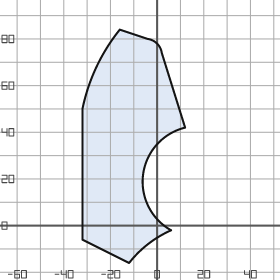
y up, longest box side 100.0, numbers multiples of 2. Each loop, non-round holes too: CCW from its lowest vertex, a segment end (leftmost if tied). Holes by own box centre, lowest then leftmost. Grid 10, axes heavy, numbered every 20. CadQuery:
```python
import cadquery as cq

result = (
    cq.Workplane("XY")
    .moveTo(-12.0, -16.0)
    .threePointArc((-4.0, -8.0), (6.0, -2.0))
    .threePointArc((-6.0, 22.0), (12.0, 42.0))
    .lineTo(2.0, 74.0)
    .threePointArc((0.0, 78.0), (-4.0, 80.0))
    .lineTo(-16.0, 84.0)
    .threePointArc((-26.0, 68.0), (-32.0, 50.0))
    .lineTo(-32.0, -6.0)
    .close()
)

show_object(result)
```